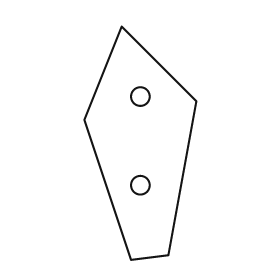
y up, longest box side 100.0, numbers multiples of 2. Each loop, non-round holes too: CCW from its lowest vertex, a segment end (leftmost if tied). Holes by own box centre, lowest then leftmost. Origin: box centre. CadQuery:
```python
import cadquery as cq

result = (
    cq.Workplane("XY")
    .moveTo(-4.0, -50.0)
    .lineTo(12.0, -48.0)
    .lineTo(24.0, 18.0)
    .lineTo(-8.0, 50.0)
    .lineTo(-24.0, 10.0)
    .close()
    .moveTo(0.0, -18.0)
    .circle(4.0)
    .moveTo(0.0, 20.0)
    .circle(4.0)
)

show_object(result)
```